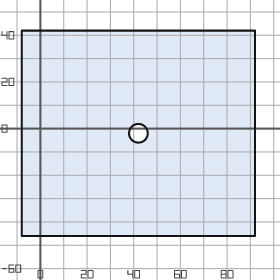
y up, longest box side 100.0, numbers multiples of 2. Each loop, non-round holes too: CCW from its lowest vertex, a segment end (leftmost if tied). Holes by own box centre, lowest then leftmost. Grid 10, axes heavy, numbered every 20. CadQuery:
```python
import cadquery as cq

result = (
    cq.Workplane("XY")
    .moveTo(-8.0, -46.0)
    .lineTo(92.0, -46.0)
    .lineTo(92.0, 42.0)
    .lineTo(-8.0, 42.0)
    .close()
    .moveTo(42.0, -2.0)
    .circle(4.0)
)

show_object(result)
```